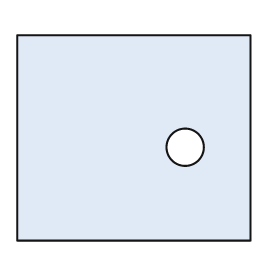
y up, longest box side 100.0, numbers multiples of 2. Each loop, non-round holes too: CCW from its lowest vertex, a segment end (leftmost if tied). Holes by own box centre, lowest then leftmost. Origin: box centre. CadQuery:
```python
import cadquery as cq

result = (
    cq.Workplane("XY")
    .moveTo(-50.0, -44.0)
    .lineTo(50.0, -44.0)
    .lineTo(50.0, 44.0)
    .lineTo(-50.0, 44.0)
    .close()
    .moveTo(22.0, -4.0)
    .circle(8.0)
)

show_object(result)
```